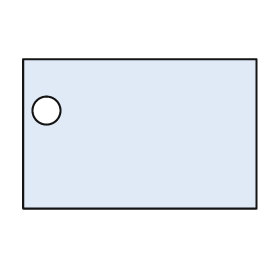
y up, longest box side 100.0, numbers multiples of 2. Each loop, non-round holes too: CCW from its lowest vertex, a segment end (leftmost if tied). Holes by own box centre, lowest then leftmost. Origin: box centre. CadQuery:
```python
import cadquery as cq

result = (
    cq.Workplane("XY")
    .moveTo(-50.0, -32.0)
    .lineTo(50.0, -32.0)
    .lineTo(50.0, 32.0)
    .lineTo(-50.0, 32.0)
    .close()
    .moveTo(-40.0, 10.0)
    .circle(6.0)
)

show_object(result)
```